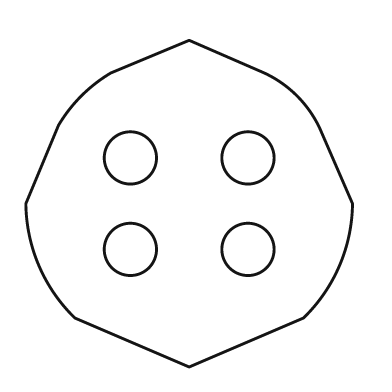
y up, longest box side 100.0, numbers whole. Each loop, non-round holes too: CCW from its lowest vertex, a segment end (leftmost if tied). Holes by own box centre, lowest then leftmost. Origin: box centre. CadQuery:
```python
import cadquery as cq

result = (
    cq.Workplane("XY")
    .moveTo(0.0, -50.0)
    .lineTo(35.0, -35.0)
    .threePointArc((46.0, -19.0), (50.0, 0.0))
    .lineTo(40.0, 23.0)
    .threePointArc((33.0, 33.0), (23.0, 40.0))
    .lineTo(0.0, 50.0)
    .lineTo(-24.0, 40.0)
    .threePointArc((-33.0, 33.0), (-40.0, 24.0))
    .lineTo(-50.0, 0.0)
    .threePointArc((-46.0, -19.0), (-35.0, -35.0))
    .close()
    .moveTo(-18.0, -14.0)
    .circle(8.0)
    .moveTo(18.0, -14.0)
    .circle(8.0)
    .moveTo(-18.0, 14.0)
    .circle(8.0)
    .moveTo(18.0, 14.0)
    .circle(8.0)
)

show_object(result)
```